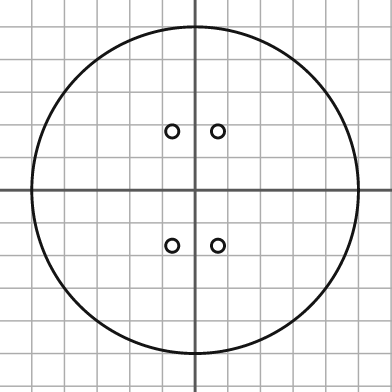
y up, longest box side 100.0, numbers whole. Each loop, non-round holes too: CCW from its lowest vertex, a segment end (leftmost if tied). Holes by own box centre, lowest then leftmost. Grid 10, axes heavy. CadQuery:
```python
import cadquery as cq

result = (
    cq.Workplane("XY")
    .moveTo(0.0, 0.0)
    .circle(50.0)
    .moveTo(-7.0, -17.0)
    .circle(2.0)
    .moveTo(7.0, -17.0)
    .circle(2.0)
    .moveTo(-7.0, 18.0)
    .circle(2.0)
    .moveTo(7.0, 18.0)
    .circle(2.0)
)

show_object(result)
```